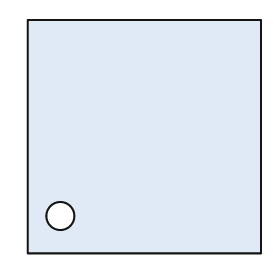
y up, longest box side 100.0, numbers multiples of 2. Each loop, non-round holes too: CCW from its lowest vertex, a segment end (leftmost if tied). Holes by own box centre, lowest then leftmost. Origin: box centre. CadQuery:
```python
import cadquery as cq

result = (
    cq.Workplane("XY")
    .moveTo(-50.0, -50.0)
    .lineTo(50.0, -50.0)
    .lineTo(50.0, 50.0)
    .lineTo(-50.0, 50.0)
    .close()
    .moveTo(-36.0, -34.0)
    .circle(6.0)
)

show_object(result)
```